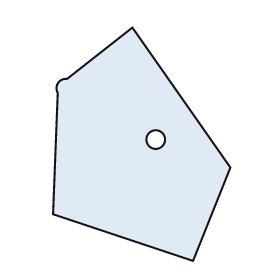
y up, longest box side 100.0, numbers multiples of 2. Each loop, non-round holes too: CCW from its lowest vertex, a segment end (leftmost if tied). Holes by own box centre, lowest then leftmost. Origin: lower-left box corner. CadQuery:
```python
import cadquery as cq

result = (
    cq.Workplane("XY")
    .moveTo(60.0, 0.0)
    .lineTo(76.0, 40.0)
    .lineTo(34.0, 100.0)
    .lineTo(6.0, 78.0)
    .threePointArc((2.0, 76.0), (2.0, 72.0))
    .lineTo(0.0, 20.0)
    .close()
    .moveTo(44.0, 52.0)
    .circle(4.0)
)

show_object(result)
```